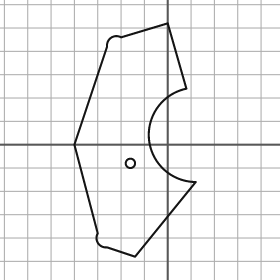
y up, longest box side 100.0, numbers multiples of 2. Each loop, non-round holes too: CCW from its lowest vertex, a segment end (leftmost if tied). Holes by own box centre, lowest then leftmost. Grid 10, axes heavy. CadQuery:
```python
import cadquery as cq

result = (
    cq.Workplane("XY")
    .moveTo(-14.0, -48.0)
    .lineTo(12.0, -16.0)
    .threePointArc((-8.0, 2.0), (8.0, 24.0))
    .lineTo(0.0, 52.0)
    .lineTo(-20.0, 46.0)
    .threePointArc((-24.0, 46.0), (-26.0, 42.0))
    .lineTo(-40.0, 0.0)
    .lineTo(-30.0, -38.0)
    .threePointArc((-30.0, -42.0), (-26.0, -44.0))
    .close()
    .moveTo(-16.0, -8.0)
    .circle(2.0)
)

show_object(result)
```